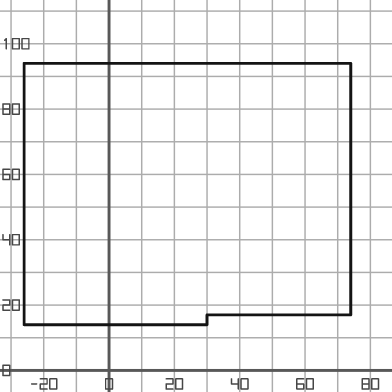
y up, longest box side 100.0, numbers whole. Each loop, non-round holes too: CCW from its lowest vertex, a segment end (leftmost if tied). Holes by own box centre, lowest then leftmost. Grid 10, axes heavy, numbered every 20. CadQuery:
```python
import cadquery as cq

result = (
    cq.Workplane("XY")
    .moveTo(-26.0, 14.0)
    .lineTo(30.0, 14.0)
    .lineTo(30.0, 17.0)
    .lineTo(74.0, 17.0)
    .lineTo(74.0, 94.0)
    .lineTo(-26.0, 94.0)
    .close()
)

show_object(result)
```